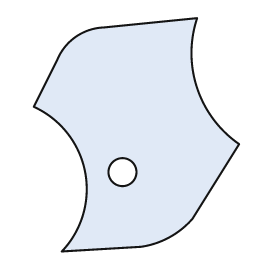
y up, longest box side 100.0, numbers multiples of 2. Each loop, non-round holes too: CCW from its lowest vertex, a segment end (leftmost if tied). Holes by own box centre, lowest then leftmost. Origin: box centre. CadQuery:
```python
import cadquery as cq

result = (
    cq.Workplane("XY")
    .moveTo(-32.0, -50.0)
    .lineTo(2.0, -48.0)
    .threePointArc((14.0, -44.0), (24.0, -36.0))
    .lineTo(44.0, -4.0)
    .threePointArc((26.0, 20.0), (26.0, 50.0))
    .lineTo(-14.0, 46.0)
    .threePointArc((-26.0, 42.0), (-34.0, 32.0))
    .lineTo(-44.0, 12.0)
    .threePointArc((-22.0, -16.0), (-32.0, -50.0))
    .close()
    .moveTo(-6.0, -16.0)
    .circle(6.0)
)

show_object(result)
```